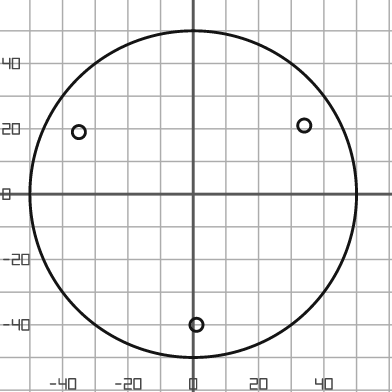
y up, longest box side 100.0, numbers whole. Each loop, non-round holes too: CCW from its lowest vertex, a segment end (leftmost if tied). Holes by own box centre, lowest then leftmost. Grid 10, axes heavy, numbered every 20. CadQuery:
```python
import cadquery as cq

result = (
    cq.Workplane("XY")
    .moveTo(0.0, 0.0)
    .circle(50.0)
    .moveTo(1.0, -40.0)
    .circle(2.0)
    .moveTo(-35.0, 19.0)
    .circle(2.0)
    .moveTo(34.0, 21.0)
    .circle(2.0)
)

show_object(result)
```